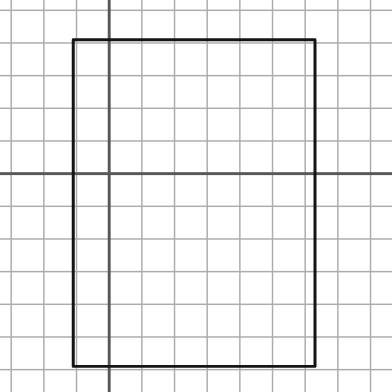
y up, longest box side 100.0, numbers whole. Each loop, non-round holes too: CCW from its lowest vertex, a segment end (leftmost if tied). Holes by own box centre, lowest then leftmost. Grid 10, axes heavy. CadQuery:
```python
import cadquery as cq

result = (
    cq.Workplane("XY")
    .moveTo(-11.0, -59.0)
    .lineTo(63.0, -59.0)
    .lineTo(63.0, 41.0)
    .lineTo(-11.0, 41.0)
    .close()
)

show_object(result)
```